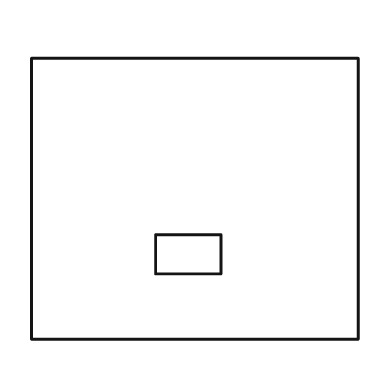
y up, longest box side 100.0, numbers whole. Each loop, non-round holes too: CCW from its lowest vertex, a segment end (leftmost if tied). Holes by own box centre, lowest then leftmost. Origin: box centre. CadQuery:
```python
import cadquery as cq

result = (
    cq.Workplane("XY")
    .moveTo(-50.0, -43.0)
    .lineTo(50.0, -43.0)
    .lineTo(50.0, 43.0)
    .lineTo(-50.0, 43.0)
    .close()
    .moveTo(-12.0, -23.0)
    .lineTo(8.0, -23.0)
    .lineTo(8.0, -11.0)
    .lineTo(-12.0, -11.0)
    .close()
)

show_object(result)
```